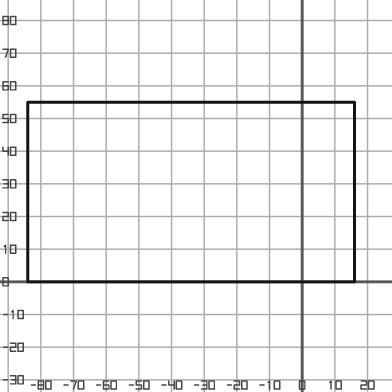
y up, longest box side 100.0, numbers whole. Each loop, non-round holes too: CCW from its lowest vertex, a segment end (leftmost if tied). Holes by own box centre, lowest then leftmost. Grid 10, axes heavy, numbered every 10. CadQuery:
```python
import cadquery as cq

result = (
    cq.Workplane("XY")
    .moveTo(-84.0, 0.0)
    .lineTo(16.0, 0.0)
    .lineTo(16.0, 55.0)
    .lineTo(-84.0, 55.0)
    .close()
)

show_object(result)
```